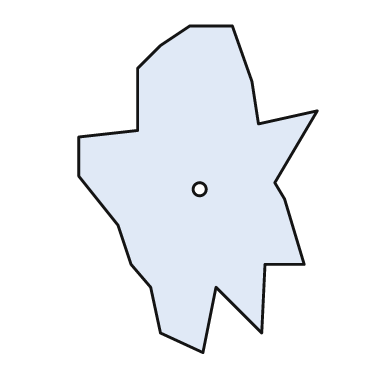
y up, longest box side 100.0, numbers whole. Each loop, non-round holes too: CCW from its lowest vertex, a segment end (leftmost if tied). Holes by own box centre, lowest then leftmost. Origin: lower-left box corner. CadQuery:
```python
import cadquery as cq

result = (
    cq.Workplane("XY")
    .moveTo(38.0, 0.0)
    .lineTo(42.0, 20.0)
    .lineTo(56.0, 6.0)
    .lineTo(57.0, 27.0)
    .lineTo(69.0, 27.0)
    .lineTo(63.0, 47.0)
    .lineTo(60.0, 52.0)
    .lineTo(73.0, 74.0)
    .lineTo(55.0, 70.0)
    .lineTo(53.0, 83.0)
    .lineTo(47.0, 100.0)
    .lineTo(34.0, 100.0)
    .lineTo(25.0, 94.0)
    .lineTo(18.0, 87.0)
    .lineTo(18.0, 68.0)
    .lineTo(0.0, 66.0)
    .lineTo(0.0, 54.0)
    .lineTo(12.0, 39.0)
    .lineTo(16.0, 27.0)
    .lineTo(22.0, 20.0)
    .lineTo(25.0, 6.0)
    .close()
    .moveTo(37.0, 50.0)
    .circle(2.0)
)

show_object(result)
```